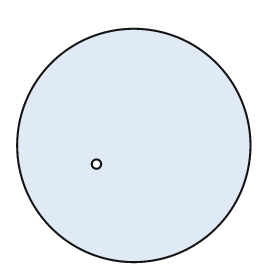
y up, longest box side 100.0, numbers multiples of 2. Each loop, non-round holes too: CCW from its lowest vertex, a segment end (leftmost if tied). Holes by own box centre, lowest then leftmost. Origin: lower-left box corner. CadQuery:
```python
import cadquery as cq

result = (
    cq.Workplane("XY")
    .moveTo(50.0, 50.0)
    .circle(50.0)
    .moveTo(34.0, 42.0)
    .circle(2.0)
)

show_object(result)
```